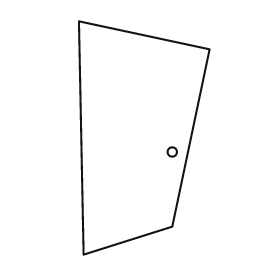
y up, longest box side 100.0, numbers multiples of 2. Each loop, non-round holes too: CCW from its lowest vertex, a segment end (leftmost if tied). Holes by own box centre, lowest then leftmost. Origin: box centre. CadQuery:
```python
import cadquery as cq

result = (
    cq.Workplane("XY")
    .moveTo(-26.0, -50.0)
    .lineTo(12.0, -38.0)
    .lineTo(28.0, 38.0)
    .lineTo(-28.0, 50.0)
    .close()
    .moveTo(12.0, -6.0)
    .circle(2.0)
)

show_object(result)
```